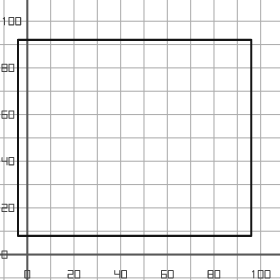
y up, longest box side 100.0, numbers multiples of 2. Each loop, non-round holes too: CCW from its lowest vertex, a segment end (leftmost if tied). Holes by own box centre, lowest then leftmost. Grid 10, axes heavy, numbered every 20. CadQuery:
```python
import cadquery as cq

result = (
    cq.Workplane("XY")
    .moveTo(-4.0, 8.0)
    .lineTo(96.0, 8.0)
    .lineTo(96.0, 92.0)
    .lineTo(-4.0, 92.0)
    .close()
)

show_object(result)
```